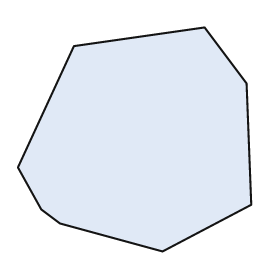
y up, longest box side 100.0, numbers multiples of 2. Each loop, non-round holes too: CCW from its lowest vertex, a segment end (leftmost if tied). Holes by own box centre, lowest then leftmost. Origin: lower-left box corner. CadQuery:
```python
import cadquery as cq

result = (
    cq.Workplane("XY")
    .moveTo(62.0, 0.0)
    .lineTo(100.0, 20.0)
    .lineTo(98.0, 72.0)
    .lineTo(80.0, 96.0)
    .lineTo(24.0, 88.0)
    .lineTo(0.0, 36.0)
    .lineTo(10.0, 18.0)
    .lineTo(18.0, 12.0)
    .close()
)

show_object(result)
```